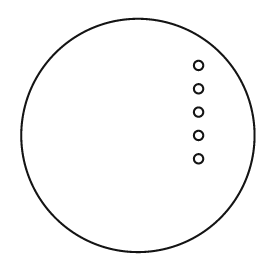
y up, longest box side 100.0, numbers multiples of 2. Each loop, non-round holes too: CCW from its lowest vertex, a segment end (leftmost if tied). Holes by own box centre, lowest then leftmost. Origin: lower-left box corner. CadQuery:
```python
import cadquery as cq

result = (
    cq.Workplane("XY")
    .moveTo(50.0, 50.0)
    .circle(50.0)
    .moveTo(76.0, 40.0)
    .circle(2.0)
    .moveTo(76.0, 50.0)
    .circle(2.0)
    .moveTo(76.0, 60.0)
    .circle(2.0)
    .moveTo(76.0, 70.0)
    .circle(2.0)
    .moveTo(76.0, 80.0)
    .circle(2.0)
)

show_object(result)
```